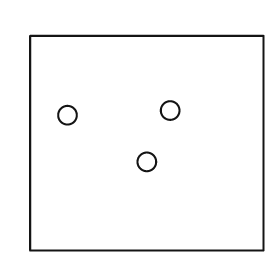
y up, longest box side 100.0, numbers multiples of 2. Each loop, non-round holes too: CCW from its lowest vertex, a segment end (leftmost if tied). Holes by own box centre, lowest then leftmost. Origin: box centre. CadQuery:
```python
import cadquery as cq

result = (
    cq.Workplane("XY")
    .moveTo(-50.0, -46.0)
    .lineTo(50.0, -46.0)
    .lineTo(50.0, 46.0)
    .lineTo(-50.0, 46.0)
    .close()
    .moveTo(0.0, -8.0)
    .circle(4.0)
    .moveTo(-34.0, 12.0)
    .circle(4.0)
    .moveTo(10.0, 14.0)
    .circle(4.0)
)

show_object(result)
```